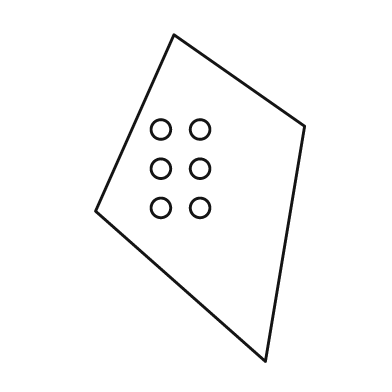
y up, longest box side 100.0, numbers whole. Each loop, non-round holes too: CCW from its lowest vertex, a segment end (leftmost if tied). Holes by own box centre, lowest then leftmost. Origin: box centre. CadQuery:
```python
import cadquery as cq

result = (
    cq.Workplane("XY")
    .moveTo(20.0, -50.0)
    .lineTo(32.0, 22.0)
    .lineTo(-8.0, 50.0)
    .lineTo(-32.0, -4.0)
    .close()
    .moveTo(-12.0, -3.0)
    .circle(3.0)
    .moveTo(0.0, -3.0)
    .circle(3.0)
    .moveTo(-12.0, 9.0)
    .circle(3.0)
    .moveTo(0.0, 9.0)
    .circle(3.0)
    .moveTo(-12.0, 21.0)
    .circle(3.0)
    .moveTo(0.0, 21.0)
    .circle(3.0)
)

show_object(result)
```